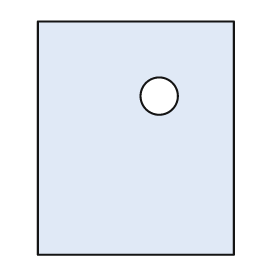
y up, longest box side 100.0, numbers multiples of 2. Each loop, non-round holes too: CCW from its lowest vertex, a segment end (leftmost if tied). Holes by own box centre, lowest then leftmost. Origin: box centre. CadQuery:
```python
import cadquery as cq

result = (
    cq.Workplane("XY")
    .moveTo(-42.0, -50.0)
    .lineTo(42.0, -50.0)
    .lineTo(42.0, 50.0)
    .lineTo(-42.0, 50.0)
    .close()
    .moveTo(10.0, 18.0)
    .circle(8.0)
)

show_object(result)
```